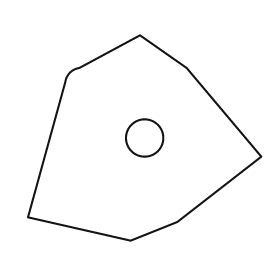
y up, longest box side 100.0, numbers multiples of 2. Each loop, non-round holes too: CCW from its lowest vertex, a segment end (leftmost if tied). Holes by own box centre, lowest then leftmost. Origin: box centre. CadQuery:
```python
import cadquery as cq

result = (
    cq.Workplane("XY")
    .moveTo(-6.0, -44.0)
    .lineTo(14.0, -36.0)
    .lineTo(50.0, -8.0)
    .lineTo(18.0, 30.0)
    .lineTo(-2.0, 44.0)
    .lineTo(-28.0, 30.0)
    .threePointArc((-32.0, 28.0), (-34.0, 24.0))
    .lineTo(-50.0, -34.0)
    .close()
    .moveTo(0.0, 0.0)
    .circle(8.0)
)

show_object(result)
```